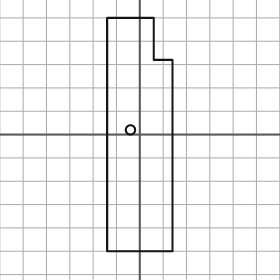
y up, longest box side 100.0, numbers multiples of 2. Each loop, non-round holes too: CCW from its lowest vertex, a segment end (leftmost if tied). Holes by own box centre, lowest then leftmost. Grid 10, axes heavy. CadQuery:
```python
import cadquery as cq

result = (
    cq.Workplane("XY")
    .moveTo(-14.0, -50.0)
    .lineTo(14.0, -50.0)
    .lineTo(14.0, 32.0)
    .lineTo(6.0, 32.0)
    .lineTo(6.0, 50.0)
    .lineTo(-14.0, 50.0)
    .close()
    .moveTo(-4.0, 2.0)
    .circle(2.0)
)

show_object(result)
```